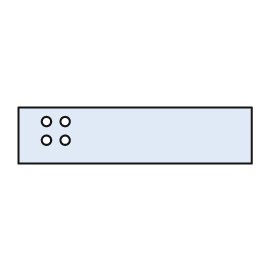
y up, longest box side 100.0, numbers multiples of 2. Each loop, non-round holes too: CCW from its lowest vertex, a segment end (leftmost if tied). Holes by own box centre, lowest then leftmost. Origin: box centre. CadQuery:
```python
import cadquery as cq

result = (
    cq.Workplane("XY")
    .moveTo(-50.0, -12.0)
    .lineTo(50.0, -12.0)
    .lineTo(50.0, 12.0)
    .lineTo(-50.0, 12.0)
    .close()
    .moveTo(-38.0, -2.0)
    .circle(2.0)
    .moveTo(-30.0, -2.0)
    .circle(2.0)
    .moveTo(-38.0, 6.0)
    .circle(2.0)
    .moveTo(-30.0, 6.0)
    .circle(2.0)
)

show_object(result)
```